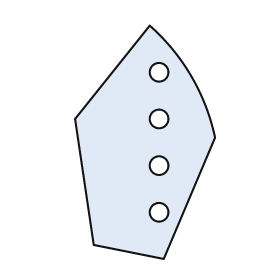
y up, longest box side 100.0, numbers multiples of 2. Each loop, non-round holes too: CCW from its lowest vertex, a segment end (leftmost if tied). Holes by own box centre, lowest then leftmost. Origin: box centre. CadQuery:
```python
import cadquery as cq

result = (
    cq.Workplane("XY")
    .moveTo(8.0, -50.0)
    .lineTo(30.0, 2.0)
    .threePointArc((20.0, 28.0), (2.0, 50.0))
    .lineTo(-30.0, 10.0)
    .lineTo(-22.0, -44.0)
    .close()
    .moveTo(6.0, -30.0)
    .circle(4.0)
    .moveTo(6.0, -10.0)
    .circle(4.0)
    .moveTo(6.0, 10.0)
    .circle(4.0)
    .moveTo(6.0, 30.0)
    .circle(4.0)
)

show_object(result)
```